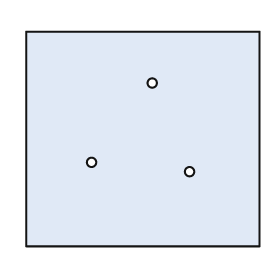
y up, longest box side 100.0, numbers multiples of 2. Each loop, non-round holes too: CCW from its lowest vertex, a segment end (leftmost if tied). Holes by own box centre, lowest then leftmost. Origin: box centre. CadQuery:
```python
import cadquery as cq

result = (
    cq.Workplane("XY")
    .moveTo(-50.0, -46.0)
    .lineTo(50.0, -46.0)
    .lineTo(50.0, 46.0)
    .lineTo(-50.0, 46.0)
    .close()
    .moveTo(20.0, -14.0)
    .circle(2.0)
    .moveTo(-22.0, -10.0)
    .circle(2.0)
    .moveTo(4.0, 24.0)
    .circle(2.0)
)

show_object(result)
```